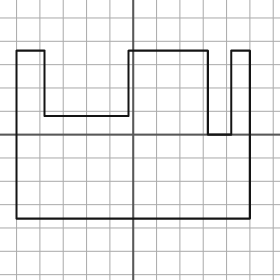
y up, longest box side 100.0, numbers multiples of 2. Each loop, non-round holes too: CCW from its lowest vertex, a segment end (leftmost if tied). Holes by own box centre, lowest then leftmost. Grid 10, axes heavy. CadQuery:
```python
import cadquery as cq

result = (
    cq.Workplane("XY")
    .moveTo(-50.0, -36.0)
    .lineTo(50.0, -36.0)
    .lineTo(50.0, 36.0)
    .lineTo(42.0, 36.0)
    .lineTo(42.0, 0.0)
    .lineTo(32.0, 0.0)
    .lineTo(32.0, 36.0)
    .lineTo(-2.0, 36.0)
    .lineTo(-2.0, 8.0)
    .lineTo(-38.0, 8.0)
    .lineTo(-38.0, 36.0)
    .lineTo(-50.0, 36.0)
    .close()
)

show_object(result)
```